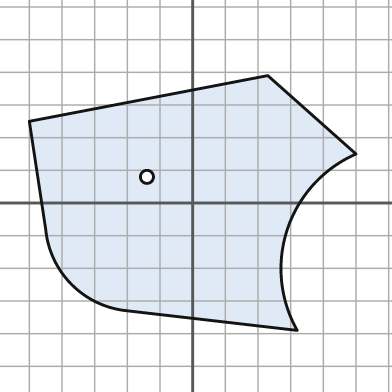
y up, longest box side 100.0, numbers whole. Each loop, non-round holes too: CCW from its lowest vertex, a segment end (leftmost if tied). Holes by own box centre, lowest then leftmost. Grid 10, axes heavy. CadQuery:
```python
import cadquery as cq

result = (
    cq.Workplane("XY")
    .moveTo(32.0, -39.0)
    .threePointArc((29.0, -8.0), (50.0, 15.0))
    .lineTo(23.0, 39.0)
    .lineTo(-50.0, 25.0)
    .lineTo(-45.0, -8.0)
    .threePointArc((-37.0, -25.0), (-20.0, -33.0))
    .close()
    .moveTo(-14.0, 8.0)
    .circle(2.0)
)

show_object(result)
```